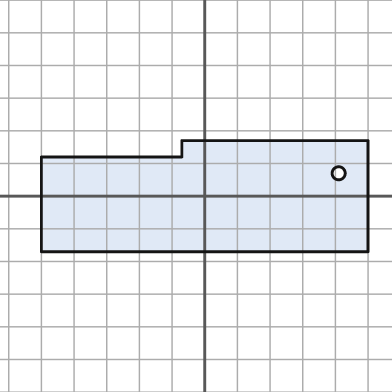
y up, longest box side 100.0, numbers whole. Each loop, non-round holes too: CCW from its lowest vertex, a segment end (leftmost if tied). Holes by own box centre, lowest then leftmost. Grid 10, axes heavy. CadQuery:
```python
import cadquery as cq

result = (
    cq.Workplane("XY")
    .moveTo(-50.0, -17.0)
    .lineTo(50.0, -17.0)
    .lineTo(50.0, 17.0)
    .lineTo(-7.0, 17.0)
    .lineTo(-7.0, 12.0)
    .lineTo(-50.0, 12.0)
    .close()
    .moveTo(41.0, 7.0)
    .circle(2.0)
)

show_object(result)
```